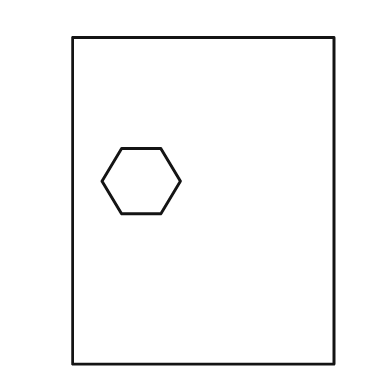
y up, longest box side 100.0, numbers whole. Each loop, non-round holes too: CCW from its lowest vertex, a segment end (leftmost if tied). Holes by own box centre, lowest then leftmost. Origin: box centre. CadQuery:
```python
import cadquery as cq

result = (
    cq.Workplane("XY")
    .moveTo(-40.0, -50.0)
    .lineTo(40.0, -50.0)
    .lineTo(40.0, 50.0)
    .lineTo(-40.0, 50.0)
    .close()
    .moveTo(-25.0, -4.0)
    .lineTo(-13.0, -4.0)
    .lineTo(-7.0, 6.0)
    .lineTo(-13.0, 16.0)
    .lineTo(-25.0, 16.0)
    .lineTo(-31.0, 6.0)
    .close()
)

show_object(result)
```